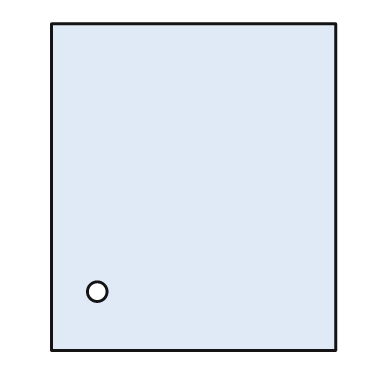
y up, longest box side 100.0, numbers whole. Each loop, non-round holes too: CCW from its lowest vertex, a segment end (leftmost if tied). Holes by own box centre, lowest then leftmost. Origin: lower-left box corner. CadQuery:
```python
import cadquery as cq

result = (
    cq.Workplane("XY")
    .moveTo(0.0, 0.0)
    .lineTo(87.0, 0.0)
    .lineTo(87.0, 100.0)
    .lineTo(0.0, 100.0)
    .close()
    .moveTo(14.0, 18.0)
    .circle(3.0)
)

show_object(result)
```